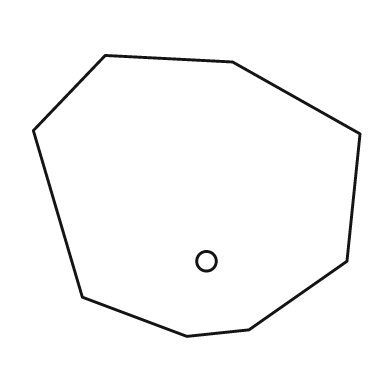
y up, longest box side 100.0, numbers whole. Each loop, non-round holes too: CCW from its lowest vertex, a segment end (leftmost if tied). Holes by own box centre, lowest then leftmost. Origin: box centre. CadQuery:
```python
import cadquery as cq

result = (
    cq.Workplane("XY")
    .moveTo(-3.0, -43.0)
    .lineTo(16.0, -41.0)
    .lineTo(46.0, -20.0)
    .lineTo(50.0, 19.0)
    .lineTo(11.0, 41.0)
    .lineTo(-28.0, 43.0)
    .lineTo(-50.0, 20.0)
    .lineTo(-35.0, -31.0)
    .close()
    .moveTo(3.0, -20.0)
    .circle(3.0)
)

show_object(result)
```